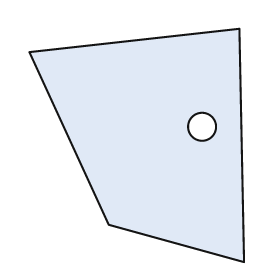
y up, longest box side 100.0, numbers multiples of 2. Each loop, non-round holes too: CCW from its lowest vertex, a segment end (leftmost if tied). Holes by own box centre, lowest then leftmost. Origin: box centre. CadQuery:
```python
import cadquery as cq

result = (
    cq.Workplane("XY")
    .moveTo(46.0, -50.0)
    .lineTo(44.0, 50.0)
    .lineTo(-46.0, 40.0)
    .lineTo(-12.0, -34.0)
    .close()
    .moveTo(28.0, 8.0)
    .circle(6.0)
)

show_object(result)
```